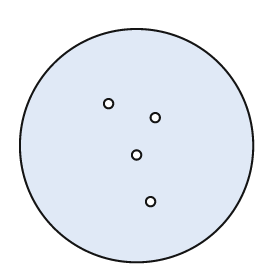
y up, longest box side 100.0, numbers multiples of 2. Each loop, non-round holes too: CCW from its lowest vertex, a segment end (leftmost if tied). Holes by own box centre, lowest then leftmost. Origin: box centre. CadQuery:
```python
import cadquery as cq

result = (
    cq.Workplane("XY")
    .moveTo(0.0, 0.0)
    .circle(50.0)
    .moveTo(6.0, -24.0)
    .circle(2.0)
    .moveTo(0.0, -4.0)
    .circle(2.0)
    .moveTo(8.0, 12.0)
    .circle(2.0)
    .moveTo(-12.0, 18.0)
    .circle(2.0)
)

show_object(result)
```